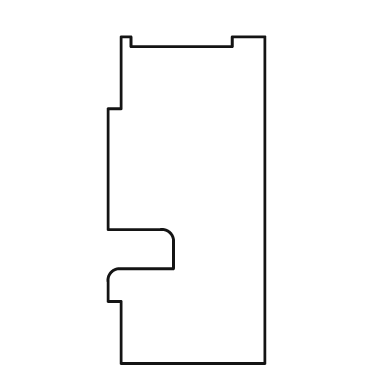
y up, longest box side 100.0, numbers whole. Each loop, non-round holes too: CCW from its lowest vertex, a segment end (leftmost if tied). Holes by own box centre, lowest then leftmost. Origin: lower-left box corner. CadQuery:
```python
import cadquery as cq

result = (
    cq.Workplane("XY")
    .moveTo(4.0, 0.0)
    .lineTo(48.0, 0.0)
    .lineTo(48.0, 100.0)
    .lineTo(38.0, 100.0)
    .lineTo(38.0, 97.0)
    .lineTo(7.0, 97.0)
    .lineTo(7.0, 100.0)
    .lineTo(4.0, 100.0)
    .lineTo(4.0, 78.0)
    .lineTo(0.0, 78.0)
    .lineTo(0.0, 41.0)
    .lineTo(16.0, 41.0)
    .threePointArc((19.0, 40.0), (20.0, 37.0))
    .lineTo(20.0, 29.0)
    .lineTo(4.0, 29.0)
    .threePointArc((1.0, 28.0), (0.0, 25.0))
    .lineTo(0.0, 19.0)
    .lineTo(4.0, 19.0)
    .close()
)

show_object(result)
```